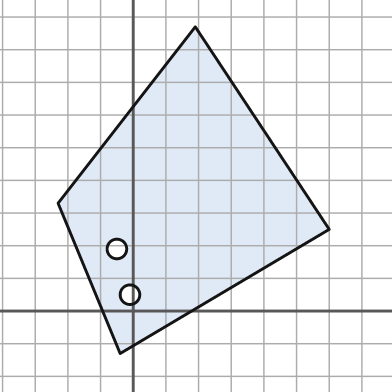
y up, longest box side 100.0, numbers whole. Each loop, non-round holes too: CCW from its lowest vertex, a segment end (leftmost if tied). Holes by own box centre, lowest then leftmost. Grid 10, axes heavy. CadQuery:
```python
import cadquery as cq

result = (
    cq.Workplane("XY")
    .moveTo(-4.0, -13.0)
    .lineTo(60.0, 25.0)
    .lineTo(19.0, 87.0)
    .lineTo(-23.0, 33.0)
    .close()
    .moveTo(-1.0, 5.0)
    .circle(3.0)
    .moveTo(-5.0, 19.0)
    .circle(3.0)
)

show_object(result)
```